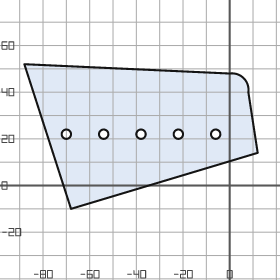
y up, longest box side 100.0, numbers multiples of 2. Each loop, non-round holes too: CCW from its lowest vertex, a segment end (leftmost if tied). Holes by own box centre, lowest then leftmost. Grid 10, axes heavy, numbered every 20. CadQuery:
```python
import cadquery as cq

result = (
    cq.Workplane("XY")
    .moveTo(-68.0, -10.0)
    .lineTo(12.0, 14.0)
    .lineTo(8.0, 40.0)
    .threePointArc((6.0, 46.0), (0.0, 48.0))
    .lineTo(-88.0, 52.0)
    .close()
    .moveTo(-70.0, 22.0)
    .circle(2.0)
    .moveTo(-54.0, 22.0)
    .circle(2.0)
    .moveTo(-38.0, 22.0)
    .circle(2.0)
    .moveTo(-22.0, 22.0)
    .circle(2.0)
    .moveTo(-6.0, 22.0)
    .circle(2.0)
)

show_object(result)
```